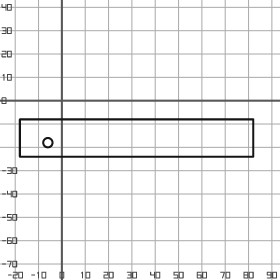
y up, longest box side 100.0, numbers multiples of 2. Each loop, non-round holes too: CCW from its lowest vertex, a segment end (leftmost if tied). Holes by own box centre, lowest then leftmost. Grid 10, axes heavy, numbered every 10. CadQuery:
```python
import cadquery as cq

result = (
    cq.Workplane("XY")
    .moveTo(-18.0, -24.0)
    .lineTo(82.0, -24.0)
    .lineTo(82.0, -8.0)
    .lineTo(-18.0, -8.0)
    .close()
    .moveTo(-6.0, -18.0)
    .circle(2.0)
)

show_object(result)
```